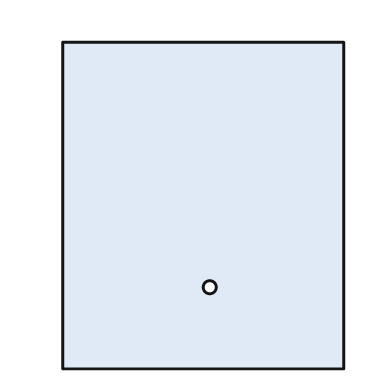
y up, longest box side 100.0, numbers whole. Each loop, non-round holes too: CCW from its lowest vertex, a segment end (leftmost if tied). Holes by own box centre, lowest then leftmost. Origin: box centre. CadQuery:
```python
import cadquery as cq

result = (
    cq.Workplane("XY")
    .moveTo(-43.0, -50.0)
    .lineTo(43.0, -50.0)
    .lineTo(43.0, 50.0)
    .lineTo(-43.0, 50.0)
    .close()
    .moveTo(2.0, -25.0)
    .circle(2.0)
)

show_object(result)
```